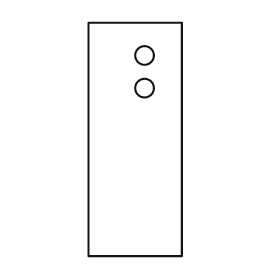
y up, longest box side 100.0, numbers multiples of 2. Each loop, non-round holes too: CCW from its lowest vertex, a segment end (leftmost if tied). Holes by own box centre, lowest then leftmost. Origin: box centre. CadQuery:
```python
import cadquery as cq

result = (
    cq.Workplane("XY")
    .moveTo(-20.0, -50.0)
    .lineTo(20.0, -50.0)
    .lineTo(20.0, 50.0)
    .lineTo(-20.0, 50.0)
    .close()
    .moveTo(4.0, 22.0)
    .circle(4.0)
    .moveTo(4.0, 36.0)
    .circle(4.0)
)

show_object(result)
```